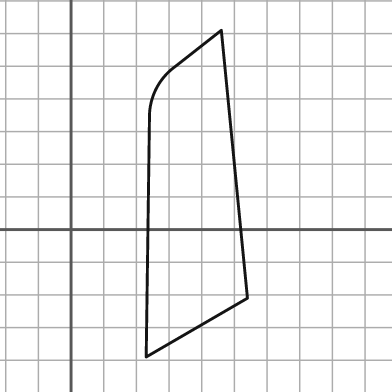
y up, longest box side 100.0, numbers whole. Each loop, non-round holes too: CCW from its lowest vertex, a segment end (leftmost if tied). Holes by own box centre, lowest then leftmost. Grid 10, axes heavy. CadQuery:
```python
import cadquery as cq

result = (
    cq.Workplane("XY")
    .moveTo(23.0, -39.0)
    .lineTo(54.0, -21.0)
    .lineTo(46.0, 61.0)
    .lineTo(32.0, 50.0)
    .threePointArc((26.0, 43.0), (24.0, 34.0))
    .close()
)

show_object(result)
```